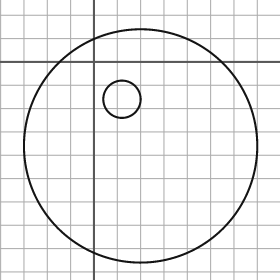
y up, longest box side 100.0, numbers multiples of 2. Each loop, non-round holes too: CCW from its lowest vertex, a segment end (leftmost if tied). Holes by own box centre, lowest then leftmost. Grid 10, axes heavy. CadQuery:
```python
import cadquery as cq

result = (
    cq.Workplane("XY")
    .moveTo(20.0, -36.0)
    .circle(50.0)
    .moveTo(12.0, -16.0)
    .circle(8.0)
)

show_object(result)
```